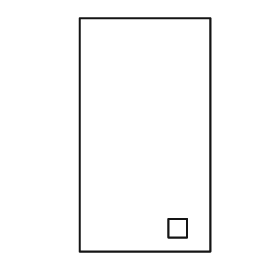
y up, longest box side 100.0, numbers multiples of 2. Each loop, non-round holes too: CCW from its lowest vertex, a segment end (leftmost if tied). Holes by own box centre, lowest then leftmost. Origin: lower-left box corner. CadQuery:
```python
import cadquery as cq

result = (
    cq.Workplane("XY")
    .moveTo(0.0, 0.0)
    .lineTo(56.0, 0.0)
    .lineTo(56.0, 100.0)
    .lineTo(0.0, 100.0)
    .close()
    .moveTo(38.0, 6.0)
    .lineTo(46.0, 6.0)
    .lineTo(46.0, 14.0)
    .lineTo(38.0, 14.0)
    .close()
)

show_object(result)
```